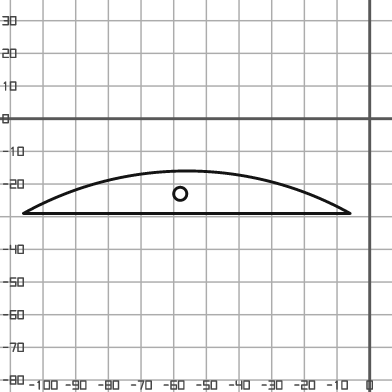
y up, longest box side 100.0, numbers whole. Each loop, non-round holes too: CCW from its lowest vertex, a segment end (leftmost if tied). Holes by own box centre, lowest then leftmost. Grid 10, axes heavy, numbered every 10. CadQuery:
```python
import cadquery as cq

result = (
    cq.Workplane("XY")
    .moveTo(-106.0, -29.0)
    .lineTo(-6.0, -29.0)
    .threePointArc((-56.0, -16.0), (-106.0, -29.0))
    .close()
    .moveTo(-58.0, -23.0)
    .circle(2.0)
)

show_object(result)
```